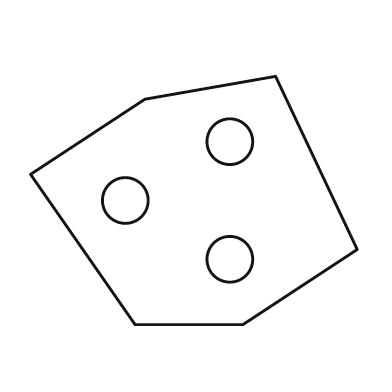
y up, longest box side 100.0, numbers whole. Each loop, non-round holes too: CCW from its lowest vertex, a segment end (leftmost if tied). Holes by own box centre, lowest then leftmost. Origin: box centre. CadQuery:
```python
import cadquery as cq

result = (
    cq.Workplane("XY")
    .moveTo(-18.0, -38.0)
    .lineTo(15.0, -38.0)
    .lineTo(50.0, -15.0)
    .lineTo(25.0, 38.0)
    .lineTo(-15.0, 31.0)
    .lineTo(-50.0, 8.0)
    .close()
    .moveTo(11.0, -18.0)
    .circle(7.0)
    .moveTo(-21.0, 0.0)
    .circle(7.0)
    .moveTo(11.0, 18.0)
    .circle(7.0)
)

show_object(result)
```